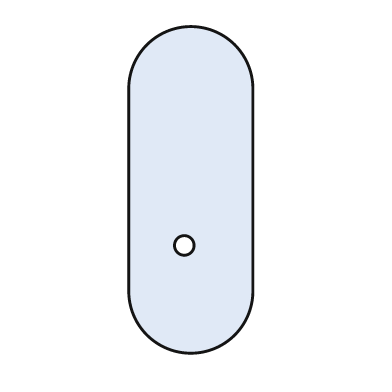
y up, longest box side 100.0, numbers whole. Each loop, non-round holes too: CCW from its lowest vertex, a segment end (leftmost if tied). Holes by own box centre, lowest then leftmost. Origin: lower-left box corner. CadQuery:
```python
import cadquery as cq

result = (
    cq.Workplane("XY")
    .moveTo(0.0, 19.0)
    .threePointArc((19.0, 0.0), (38.0, 19.0))
    .lineTo(38.0, 81.0)
    .threePointArc((19.0, 100.0), (0.0, 81.0))
    .close()
    .moveTo(17.0, 33.0)
    .circle(3.0)
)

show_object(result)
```